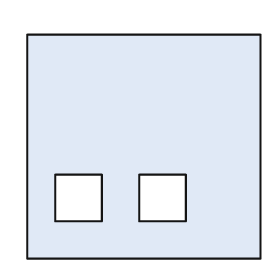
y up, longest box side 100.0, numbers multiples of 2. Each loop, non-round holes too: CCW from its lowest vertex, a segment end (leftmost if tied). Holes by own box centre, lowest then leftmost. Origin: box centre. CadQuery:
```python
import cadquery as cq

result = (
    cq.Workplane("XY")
    .moveTo(-50.0, -48.0)
    .lineTo(50.0, -48.0)
    .lineTo(50.0, 48.0)
    .lineTo(-50.0, 48.0)
    .close()
    .moveTo(-38.0, -32.0)
    .lineTo(-18.0, -32.0)
    .lineTo(-18.0, -12.0)
    .lineTo(-38.0, -12.0)
    .close()
    .moveTo(-2.0, -32.0)
    .lineTo(18.0, -32.0)
    .lineTo(18.0, -12.0)
    .lineTo(-2.0, -12.0)
    .close()
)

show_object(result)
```